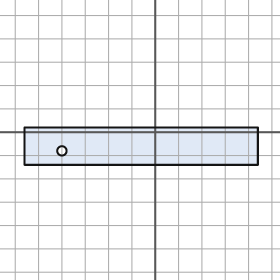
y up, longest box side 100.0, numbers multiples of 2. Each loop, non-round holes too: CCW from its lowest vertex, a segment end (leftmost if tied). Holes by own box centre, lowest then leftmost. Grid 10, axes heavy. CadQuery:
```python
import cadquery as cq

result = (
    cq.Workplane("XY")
    .moveTo(-56.0, -14.0)
    .lineTo(44.0, -14.0)
    .lineTo(44.0, 2.0)
    .lineTo(-56.0, 2.0)
    .close()
    .moveTo(-40.0, -8.0)
    .circle(2.0)
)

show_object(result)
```